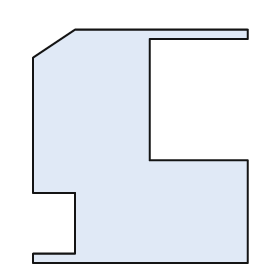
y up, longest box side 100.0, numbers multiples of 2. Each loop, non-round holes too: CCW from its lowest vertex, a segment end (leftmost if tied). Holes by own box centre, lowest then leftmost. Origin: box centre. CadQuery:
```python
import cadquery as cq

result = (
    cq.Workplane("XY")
    .moveTo(-46.0, -50.0)
    .lineTo(46.0, -50.0)
    .lineTo(46.0, -6.0)
    .lineTo(4.0, -6.0)
    .lineTo(4.0, 46.0)
    .lineTo(46.0, 46.0)
    .lineTo(46.0, 50.0)
    .lineTo(-28.0, 50.0)
    .lineTo(-46.0, 38.0)
    .lineTo(-46.0, -20.0)
    .lineTo(-28.0, -20.0)
    .lineTo(-28.0, -46.0)
    .lineTo(-46.0, -46.0)
    .close()
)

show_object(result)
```